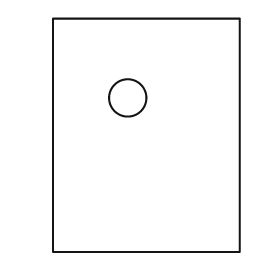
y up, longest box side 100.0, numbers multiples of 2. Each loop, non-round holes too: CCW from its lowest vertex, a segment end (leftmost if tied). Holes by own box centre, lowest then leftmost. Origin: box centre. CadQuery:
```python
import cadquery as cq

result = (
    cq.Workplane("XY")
    .moveTo(-40.0, -50.0)
    .lineTo(40.0, -50.0)
    .lineTo(40.0, 50.0)
    .lineTo(-40.0, 50.0)
    .close()
    .moveTo(-8.0, 16.0)
    .circle(8.0)
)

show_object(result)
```